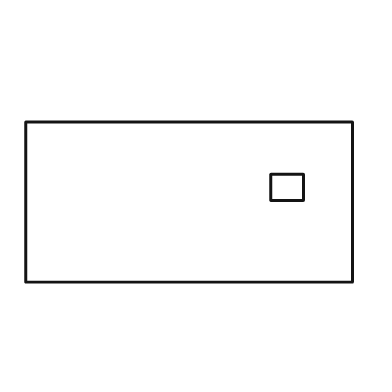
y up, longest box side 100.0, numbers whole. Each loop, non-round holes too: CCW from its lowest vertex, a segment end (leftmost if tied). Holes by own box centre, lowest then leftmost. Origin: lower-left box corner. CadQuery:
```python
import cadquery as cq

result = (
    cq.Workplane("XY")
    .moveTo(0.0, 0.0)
    .lineTo(100.0, 0.0)
    .lineTo(100.0, 49.0)
    .lineTo(0.0, 49.0)
    .close()
    .moveTo(75.0, 25.0)
    .lineTo(85.0, 25.0)
    .lineTo(85.0, 33.0)
    .lineTo(75.0, 33.0)
    .close()
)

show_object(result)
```